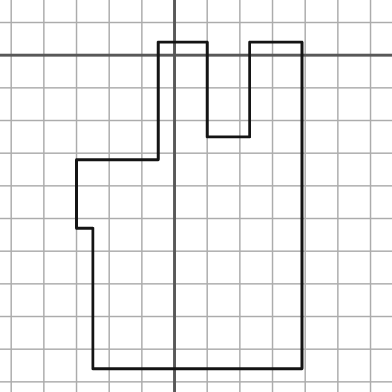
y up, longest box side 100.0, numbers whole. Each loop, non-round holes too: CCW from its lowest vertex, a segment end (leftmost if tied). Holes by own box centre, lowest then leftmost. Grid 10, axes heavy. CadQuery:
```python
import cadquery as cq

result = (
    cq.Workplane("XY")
    .moveTo(-25.0, -96.0)
    .lineTo(39.0, -96.0)
    .lineTo(39.0, 4.0)
    .lineTo(23.0, 4.0)
    .lineTo(23.0, -25.0)
    .lineTo(10.0, -25.0)
    .lineTo(10.0, 4.0)
    .lineTo(-5.0, 4.0)
    .lineTo(-5.0, -32.0)
    .lineTo(-30.0, -32.0)
    .lineTo(-30.0, -53.0)
    .lineTo(-25.0, -53.0)
    .close()
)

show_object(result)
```